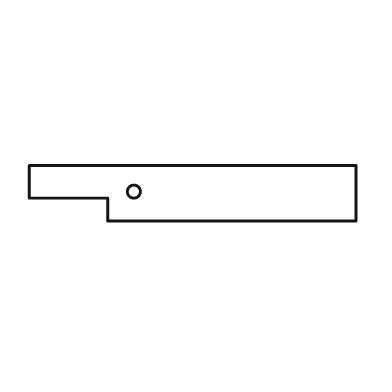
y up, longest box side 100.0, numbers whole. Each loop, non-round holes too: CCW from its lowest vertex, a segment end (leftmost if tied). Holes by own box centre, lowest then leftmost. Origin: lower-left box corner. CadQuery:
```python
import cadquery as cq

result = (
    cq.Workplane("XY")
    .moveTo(24.0, 0.0)
    .lineTo(100.0, 0.0)
    .lineTo(100.0, 17.0)
    .lineTo(0.0, 17.0)
    .lineTo(0.0, 7.0)
    .lineTo(24.0, 7.0)
    .close()
    .moveTo(32.0, 9.0)
    .circle(2.0)
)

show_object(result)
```